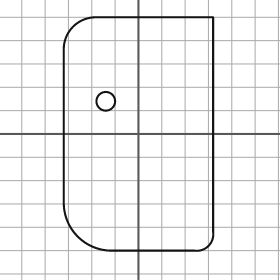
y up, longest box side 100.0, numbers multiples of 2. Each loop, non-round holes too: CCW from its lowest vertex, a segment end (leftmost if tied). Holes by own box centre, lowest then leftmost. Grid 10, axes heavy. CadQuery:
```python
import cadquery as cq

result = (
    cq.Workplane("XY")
    .moveTo(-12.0, -50.0)
    .lineTo(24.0, -50.0)
    .threePointArc((30.0, -48.0), (32.0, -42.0))
    .lineTo(32.0, 50.0)
    .lineTo(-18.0, 50.0)
    .threePointArc((-28.0, 46.0), (-32.0, 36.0))
    .lineTo(-32.0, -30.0)
    .threePointArc((-26.0, -44.0), (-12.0, -50.0))
    .close()
    .moveTo(-14.0, 14.0)
    .circle(4.0)
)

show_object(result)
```